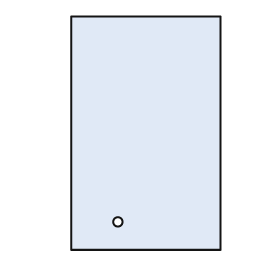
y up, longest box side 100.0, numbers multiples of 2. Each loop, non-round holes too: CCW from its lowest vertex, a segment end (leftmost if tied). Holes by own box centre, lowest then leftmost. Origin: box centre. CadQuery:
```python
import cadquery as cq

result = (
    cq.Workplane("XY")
    .moveTo(-32.0, -50.0)
    .lineTo(32.0, -50.0)
    .lineTo(32.0, 50.0)
    .lineTo(-32.0, 50.0)
    .close()
    .moveTo(-12.0, -38.0)
    .circle(2.0)
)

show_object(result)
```